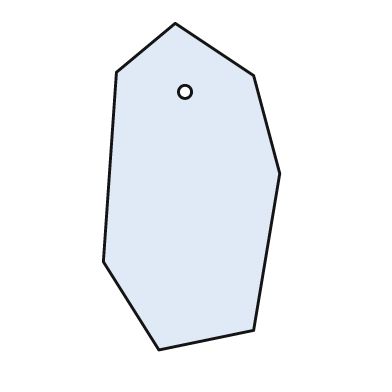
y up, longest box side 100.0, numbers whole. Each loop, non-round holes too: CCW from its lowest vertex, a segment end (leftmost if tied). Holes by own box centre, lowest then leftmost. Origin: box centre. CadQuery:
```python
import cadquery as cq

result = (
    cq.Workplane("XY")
    .moveTo(-10.0, -50.0)
    .lineTo(19.0, -44.0)
    .lineTo(27.0, 4.0)
    .lineTo(19.0, 34.0)
    .lineTo(-5.0, 50.0)
    .lineTo(-23.0, 35.0)
    .lineTo(-27.0, -23.0)
    .close()
    .moveTo(-2.0, 29.0)
    .circle(2.0)
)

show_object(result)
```